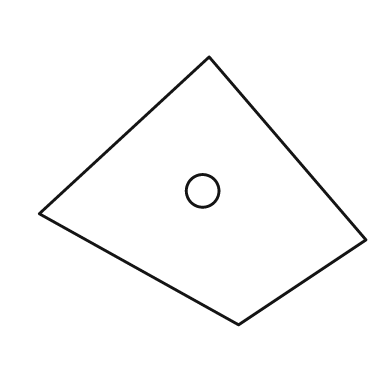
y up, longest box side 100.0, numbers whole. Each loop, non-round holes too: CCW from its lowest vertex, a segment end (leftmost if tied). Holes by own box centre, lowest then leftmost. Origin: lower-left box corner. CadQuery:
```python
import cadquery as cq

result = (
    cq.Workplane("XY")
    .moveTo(61.0, 0.0)
    .lineTo(100.0, 26.0)
    .lineTo(52.0, 82.0)
    .lineTo(0.0, 34.0)
    .close()
    .moveTo(50.0, 41.0)
    .circle(5.0)
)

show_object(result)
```